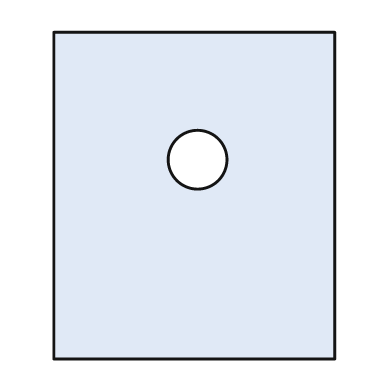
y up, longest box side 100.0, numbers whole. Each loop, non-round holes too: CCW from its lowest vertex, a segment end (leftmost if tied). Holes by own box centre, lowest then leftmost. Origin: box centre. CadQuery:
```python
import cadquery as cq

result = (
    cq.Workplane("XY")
    .moveTo(-43.0, -50.0)
    .lineTo(43.0, -50.0)
    .lineTo(43.0, 50.0)
    .lineTo(-43.0, 50.0)
    .close()
    .moveTo(1.0, 11.0)
    .circle(9.0)
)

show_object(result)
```